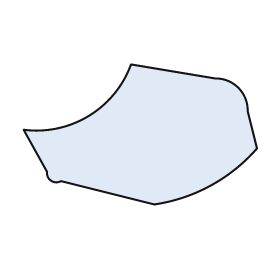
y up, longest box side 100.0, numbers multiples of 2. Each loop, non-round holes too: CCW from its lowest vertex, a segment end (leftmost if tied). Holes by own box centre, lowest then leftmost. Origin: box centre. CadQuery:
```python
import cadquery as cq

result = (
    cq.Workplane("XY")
    .moveTo(6.0, -30.0)
    .threePointArc((30.0, -22.0), (50.0, -6.0))
    .lineTo(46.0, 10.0)
    .threePointArc((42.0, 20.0), (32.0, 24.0))
    .lineTo(-4.0, 30.0)
    .threePointArc((-22.0, 8.0), (-50.0, 2.0))
    .lineTo(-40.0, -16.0)
    .threePointArc((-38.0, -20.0), (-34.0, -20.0))
    .close()
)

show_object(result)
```